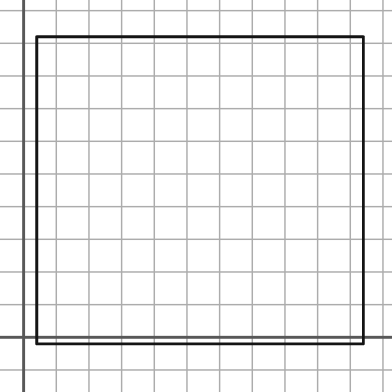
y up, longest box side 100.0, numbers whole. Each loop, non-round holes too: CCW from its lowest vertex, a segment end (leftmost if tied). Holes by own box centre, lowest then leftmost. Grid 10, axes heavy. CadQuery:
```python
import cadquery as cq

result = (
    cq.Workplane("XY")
    .moveTo(4.0, -2.0)
    .lineTo(104.0, -2.0)
    .lineTo(104.0, 92.0)
    .lineTo(4.0, 92.0)
    .close()
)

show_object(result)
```